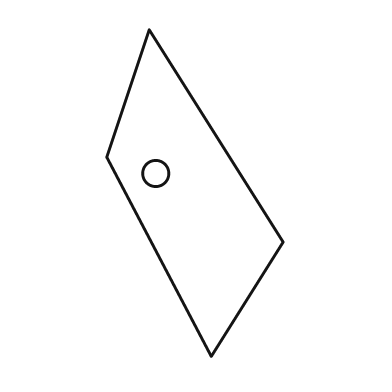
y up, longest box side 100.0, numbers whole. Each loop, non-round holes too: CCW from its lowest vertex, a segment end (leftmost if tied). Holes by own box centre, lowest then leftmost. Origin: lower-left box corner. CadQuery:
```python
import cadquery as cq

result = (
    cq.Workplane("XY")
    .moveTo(32.0, 0.0)
    .lineTo(54.0, 35.0)
    .lineTo(13.0, 100.0)
    .lineTo(0.0, 61.0)
    .close()
    .moveTo(15.0, 56.0)
    .circle(4.0)
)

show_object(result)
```